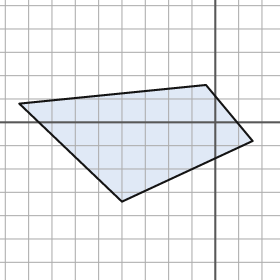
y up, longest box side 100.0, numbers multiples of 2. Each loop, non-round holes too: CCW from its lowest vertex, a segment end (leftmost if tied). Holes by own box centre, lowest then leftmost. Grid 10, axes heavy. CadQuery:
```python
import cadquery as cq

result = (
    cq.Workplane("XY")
    .moveTo(-40.0, -34.0)
    .lineTo(16.0, -8.0)
    .lineTo(-4.0, 16.0)
    .lineTo(-84.0, 8.0)
    .close()
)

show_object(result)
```